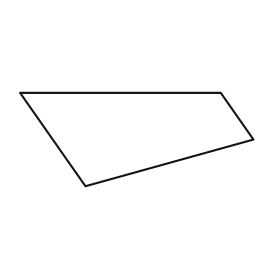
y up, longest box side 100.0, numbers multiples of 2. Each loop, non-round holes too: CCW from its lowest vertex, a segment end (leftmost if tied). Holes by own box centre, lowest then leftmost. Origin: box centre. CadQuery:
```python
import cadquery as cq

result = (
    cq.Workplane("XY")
    .moveTo(-22.0, -20.0)
    .lineTo(50.0, 0.0)
    .lineTo(36.0, 20.0)
    .lineTo(-50.0, 20.0)
    .close()
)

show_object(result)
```